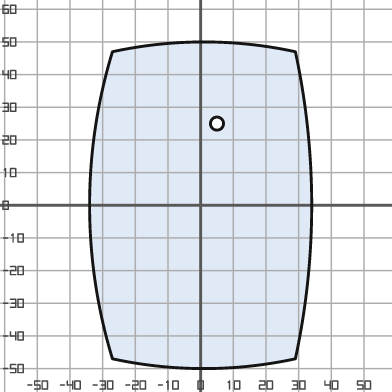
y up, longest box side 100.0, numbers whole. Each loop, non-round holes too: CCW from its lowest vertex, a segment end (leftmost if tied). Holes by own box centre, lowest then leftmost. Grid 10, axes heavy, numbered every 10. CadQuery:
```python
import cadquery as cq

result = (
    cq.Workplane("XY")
    .moveTo(-27.0, -47.0)
    .threePointArc((1.0, -50.0), (29.0, -47.0))
    .threePointArc((34.0, 0.0), (29.0, 47.0))
    .threePointArc((1.0, 50.0), (-27.0, 47.0))
    .threePointArc((-34.0, 0.0), (-27.0, -47.0))
    .close()
    .moveTo(5.0, 25.0)
    .circle(2.0)
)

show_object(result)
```